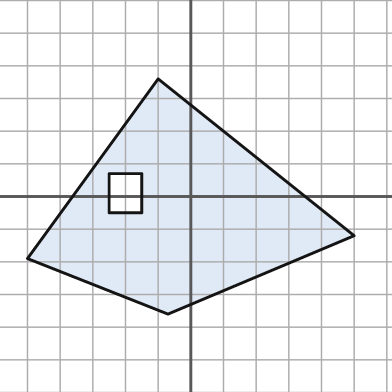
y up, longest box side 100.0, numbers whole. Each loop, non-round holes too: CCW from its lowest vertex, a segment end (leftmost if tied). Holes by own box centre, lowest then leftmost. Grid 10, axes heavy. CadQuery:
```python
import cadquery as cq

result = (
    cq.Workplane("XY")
    .moveTo(-7.0, -36.0)
    .lineTo(50.0, -12.0)
    .lineTo(-10.0, 36.0)
    .lineTo(-50.0, -19.0)
    .close()
    .moveTo(-25.0, -5.0)
    .lineTo(-15.0, -5.0)
    .lineTo(-15.0, 7.0)
    .lineTo(-25.0, 7.0)
    .close()
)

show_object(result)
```